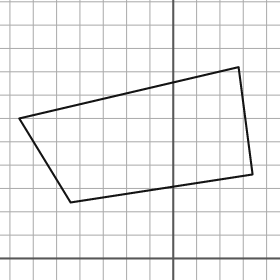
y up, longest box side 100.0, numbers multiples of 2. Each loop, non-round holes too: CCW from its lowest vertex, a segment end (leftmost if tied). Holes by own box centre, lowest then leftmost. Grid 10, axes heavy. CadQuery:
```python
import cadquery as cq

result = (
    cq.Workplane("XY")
    .moveTo(-44.0, 24.0)
    .lineTo(34.0, 36.0)
    .lineTo(28.0, 82.0)
    .lineTo(-66.0, 60.0)
    .close()
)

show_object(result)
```